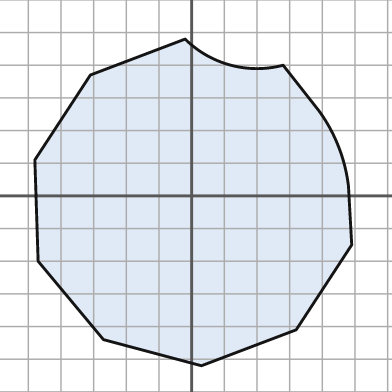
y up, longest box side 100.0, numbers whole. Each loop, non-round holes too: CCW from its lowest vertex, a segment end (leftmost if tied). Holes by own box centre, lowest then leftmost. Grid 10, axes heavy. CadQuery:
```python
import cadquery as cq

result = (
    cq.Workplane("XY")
    .moveTo(3.0, -52.0)
    .lineTo(32.0, -41.0)
    .lineTo(49.0, -15.0)
    .lineTo(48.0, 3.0)
    .threePointArc((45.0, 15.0), (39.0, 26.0))
    .lineTo(28.0, 40.0)
    .threePointArc((12.0, 40.0), (-2.0, 48.0))
    .lineTo(-31.0, 37.0)
    .lineTo(-48.0, 11.0)
    .lineTo(-47.0, -20.0)
    .lineTo(-27.0, -44.0)
    .close()
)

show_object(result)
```